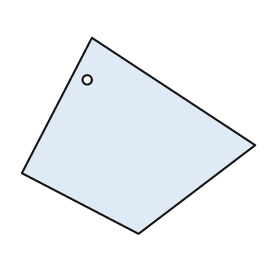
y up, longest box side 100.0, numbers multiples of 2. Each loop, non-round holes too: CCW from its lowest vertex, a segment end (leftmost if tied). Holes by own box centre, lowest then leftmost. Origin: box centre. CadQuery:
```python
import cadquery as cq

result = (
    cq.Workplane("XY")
    .moveTo(0.0, -42.0)
    .lineTo(50.0, -4.0)
    .lineTo(-20.0, 42.0)
    .lineTo(-50.0, -16.0)
    .close()
    .moveTo(-22.0, 24.0)
    .circle(2.0)
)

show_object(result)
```